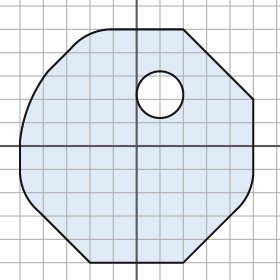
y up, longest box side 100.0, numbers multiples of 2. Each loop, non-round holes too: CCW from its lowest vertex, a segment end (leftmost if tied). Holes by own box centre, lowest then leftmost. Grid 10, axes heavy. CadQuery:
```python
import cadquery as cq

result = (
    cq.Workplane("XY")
    .moveTo(-20.0, -50.0)
    .lineTo(20.0, -50.0)
    .lineTo(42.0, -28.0)
    .threePointArc((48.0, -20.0), (50.0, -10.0))
    .lineTo(50.0, 20.0)
    .lineTo(20.0, 50.0)
    .lineTo(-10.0, 50.0)
    .threePointArc((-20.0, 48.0), (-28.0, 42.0))
    .lineTo(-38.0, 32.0)
    .threePointArc((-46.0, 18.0), (-50.0, 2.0))
    .lineTo(-50.0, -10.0)
    .threePointArc((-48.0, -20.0), (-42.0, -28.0))
    .close()
    .moveTo(10.0, 22.0)
    .circle(10.0)
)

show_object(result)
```